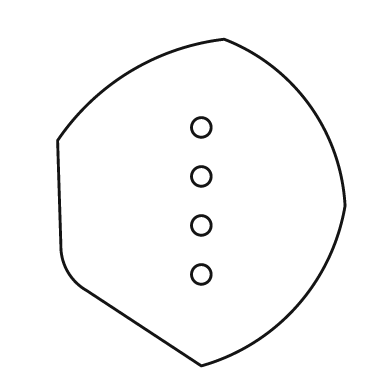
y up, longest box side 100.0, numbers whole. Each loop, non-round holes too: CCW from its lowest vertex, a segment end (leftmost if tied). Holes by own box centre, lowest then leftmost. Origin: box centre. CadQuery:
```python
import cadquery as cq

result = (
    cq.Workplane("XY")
    .moveTo(0.0, -50.0)
    .threePointArc((29.0, -32.0), (44.0, -1.0))
    .threePointArc((33.0, 30.0), (7.0, 50.0))
    .threePointArc((-22.0, 40.0), (-44.0, 19.0))
    .lineTo(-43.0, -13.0)
    .threePointArc((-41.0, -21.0), (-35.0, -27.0))
    .close()
    .moveTo(0.0, -22.0)
    .circle(3.0)
    .moveTo(0.0, -7.0)
    .circle(3.0)
    .moveTo(0.0, 8.0)
    .circle(3.0)
    .moveTo(0.0, 23.0)
    .circle(3.0)
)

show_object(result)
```